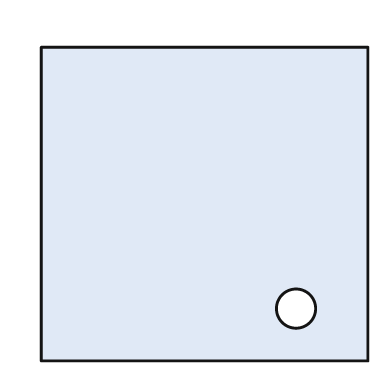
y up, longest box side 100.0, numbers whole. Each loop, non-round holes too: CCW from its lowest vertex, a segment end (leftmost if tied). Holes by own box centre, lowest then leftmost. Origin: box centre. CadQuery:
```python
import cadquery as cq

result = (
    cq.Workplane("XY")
    .moveTo(-50.0, -48.0)
    .lineTo(50.0, -48.0)
    .lineTo(50.0, 48.0)
    .lineTo(-50.0, 48.0)
    .close()
    .moveTo(28.0, -32.0)
    .circle(6.0)
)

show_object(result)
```